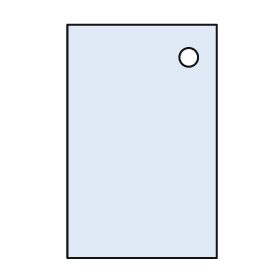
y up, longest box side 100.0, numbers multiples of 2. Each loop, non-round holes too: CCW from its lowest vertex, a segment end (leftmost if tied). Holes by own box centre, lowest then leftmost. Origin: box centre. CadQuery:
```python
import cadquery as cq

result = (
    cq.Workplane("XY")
    .moveTo(-32.0, -50.0)
    .lineTo(32.0, -50.0)
    .lineTo(32.0, 50.0)
    .lineTo(-32.0, 50.0)
    .close()
    .moveTo(20.0, 36.0)
    .circle(4.0)
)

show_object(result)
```